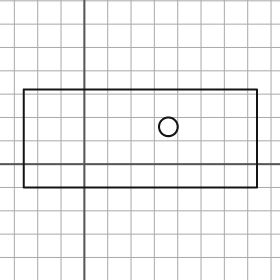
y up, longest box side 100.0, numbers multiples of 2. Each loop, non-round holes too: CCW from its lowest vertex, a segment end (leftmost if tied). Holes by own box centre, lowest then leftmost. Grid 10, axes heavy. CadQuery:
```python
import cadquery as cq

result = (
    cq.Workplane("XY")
    .moveTo(-26.0, -10.0)
    .lineTo(74.0, -10.0)
    .lineTo(74.0, 32.0)
    .lineTo(-26.0, 32.0)
    .close()
    .moveTo(36.0, 16.0)
    .circle(4.0)
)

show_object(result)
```